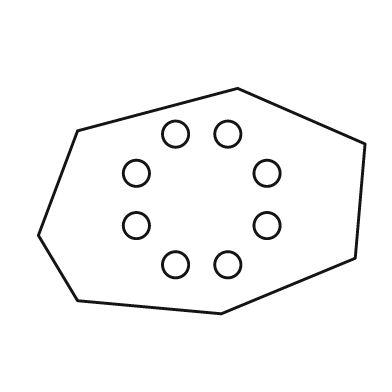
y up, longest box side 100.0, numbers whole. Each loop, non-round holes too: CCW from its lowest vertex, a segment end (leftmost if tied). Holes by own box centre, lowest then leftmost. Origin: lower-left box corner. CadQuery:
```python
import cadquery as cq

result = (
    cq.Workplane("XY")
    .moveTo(56.0, 0.0)
    .lineTo(97.0, 17.0)
    .lineTo(100.0, 52.0)
    .lineTo(61.0, 69.0)
    .lineTo(12.0, 56.0)
    .lineTo(0.0, 24.0)
    .lineTo(12.0, 4.0)
    .close()
    .moveTo(42.0, 15.0)
    .circle(4.0)
    .moveTo(58.0, 15.0)
    .circle(4.0)
    .moveTo(30.0, 27.0)
    .circle(4.0)
    .moveTo(70.0, 27.0)
    .circle(4.0)
    .moveTo(30.0, 43.0)
    .circle(4.0)
    .moveTo(70.0, 43.0)
    .circle(4.0)
    .moveTo(42.0, 55.0)
    .circle(4.0)
    .moveTo(58.0, 55.0)
    .circle(4.0)
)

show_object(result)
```